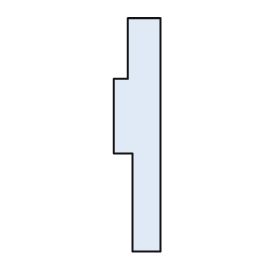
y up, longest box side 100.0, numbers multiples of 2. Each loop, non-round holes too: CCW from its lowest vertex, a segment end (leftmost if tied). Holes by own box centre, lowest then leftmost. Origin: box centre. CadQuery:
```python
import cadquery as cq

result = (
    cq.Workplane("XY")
    .moveTo(-2.0, -50.0)
    .lineTo(10.0, -50.0)
    .lineTo(10.0, 50.0)
    .lineTo(-4.0, 50.0)
    .lineTo(-4.0, 24.0)
    .lineTo(-10.0, 24.0)
    .lineTo(-10.0, -8.0)
    .lineTo(-2.0, -8.0)
    .close()
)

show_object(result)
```